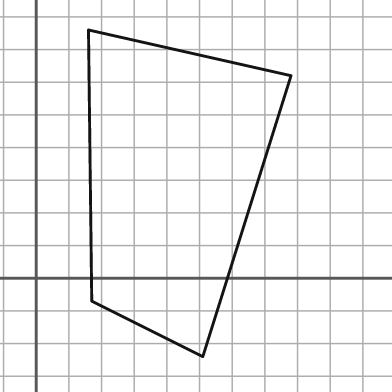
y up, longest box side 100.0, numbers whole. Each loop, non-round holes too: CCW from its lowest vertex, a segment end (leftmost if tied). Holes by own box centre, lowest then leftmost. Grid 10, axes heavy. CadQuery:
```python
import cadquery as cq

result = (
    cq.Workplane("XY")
    .moveTo(51.0, -24.0)
    .lineTo(78.0, 62.0)
    .lineTo(16.0, 76.0)
    .lineTo(17.0, -7.0)
    .close()
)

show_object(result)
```